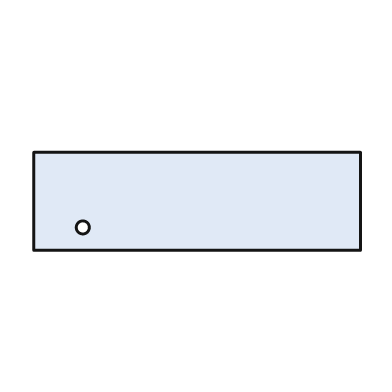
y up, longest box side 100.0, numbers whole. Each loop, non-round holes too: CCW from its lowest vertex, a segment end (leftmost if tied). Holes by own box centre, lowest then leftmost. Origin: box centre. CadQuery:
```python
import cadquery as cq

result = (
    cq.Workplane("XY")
    .moveTo(-50.0, -15.0)
    .lineTo(50.0, -15.0)
    .lineTo(50.0, 15.0)
    .lineTo(-50.0, 15.0)
    .close()
    .moveTo(-35.0, -8.0)
    .circle(2.0)
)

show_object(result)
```